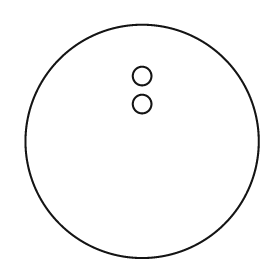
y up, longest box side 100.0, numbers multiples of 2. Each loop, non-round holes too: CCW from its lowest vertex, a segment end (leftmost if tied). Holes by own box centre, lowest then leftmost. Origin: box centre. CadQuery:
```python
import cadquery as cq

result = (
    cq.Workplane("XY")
    .moveTo(0.0, 0.0)
    .circle(50.0)
    .moveTo(0.0, 16.0)
    .circle(4.0)
    .moveTo(0.0, 28.0)
    .circle(4.0)
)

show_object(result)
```